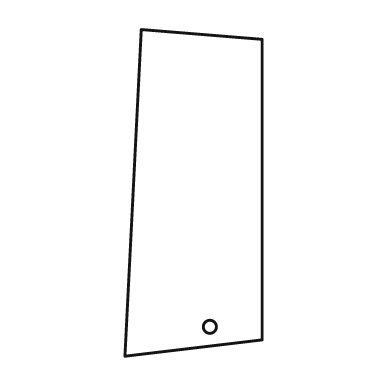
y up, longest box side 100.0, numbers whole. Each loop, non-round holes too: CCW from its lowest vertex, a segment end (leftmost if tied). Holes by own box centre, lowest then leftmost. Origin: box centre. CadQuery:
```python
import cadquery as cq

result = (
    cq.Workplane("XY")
    .moveTo(-21.0, -50.0)
    .lineTo(21.0, -45.0)
    .lineTo(21.0, 47.0)
    .lineTo(-16.0, 50.0)
    .close()
    .moveTo(5.0, -41.0)
    .circle(2.0)
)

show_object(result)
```